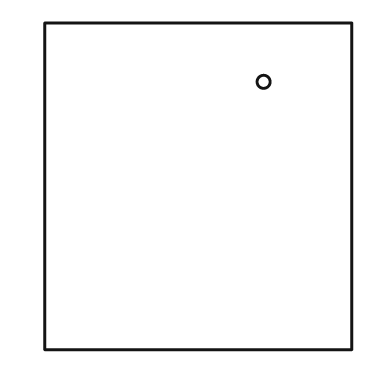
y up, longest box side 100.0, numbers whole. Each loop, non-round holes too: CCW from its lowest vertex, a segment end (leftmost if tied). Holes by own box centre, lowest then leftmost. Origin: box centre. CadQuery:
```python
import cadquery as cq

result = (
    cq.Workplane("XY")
    .moveTo(-47.0, -50.0)
    .lineTo(47.0, -50.0)
    .lineTo(47.0, 50.0)
    .lineTo(-47.0, 50.0)
    .close()
    .moveTo(20.0, 32.0)
    .circle(2.0)
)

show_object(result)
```